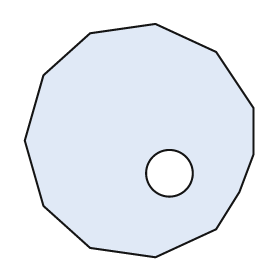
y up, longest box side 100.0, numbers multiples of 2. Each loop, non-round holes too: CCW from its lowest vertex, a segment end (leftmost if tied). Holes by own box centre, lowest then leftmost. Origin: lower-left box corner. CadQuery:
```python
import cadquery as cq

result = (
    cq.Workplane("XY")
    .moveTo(56.0, 0.0)
    .lineTo(82.0, 12.0)
    .lineTo(92.0, 28.0)
    .lineTo(98.0, 44.0)
    .lineTo(98.0, 64.0)
    .lineTo(82.0, 88.0)
    .lineTo(56.0, 100.0)
    .lineTo(28.0, 96.0)
    .lineTo(8.0, 78.0)
    .lineTo(0.0, 50.0)
    .lineTo(8.0, 22.0)
    .lineTo(28.0, 4.0)
    .close()
    .moveTo(62.0, 36.0)
    .circle(10.0)
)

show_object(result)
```